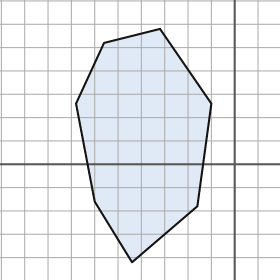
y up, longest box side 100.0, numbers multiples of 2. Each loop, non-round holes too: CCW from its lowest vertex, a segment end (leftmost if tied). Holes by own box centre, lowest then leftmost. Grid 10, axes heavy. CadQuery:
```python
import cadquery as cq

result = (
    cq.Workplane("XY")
    .moveTo(-44.0, -42.0)
    .lineTo(-16.0, -18.0)
    .lineTo(-10.0, 26.0)
    .lineTo(-32.0, 58.0)
    .lineTo(-56.0, 52.0)
    .lineTo(-68.0, 26.0)
    .lineTo(-60.0, -16.0)
    .close()
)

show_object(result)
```